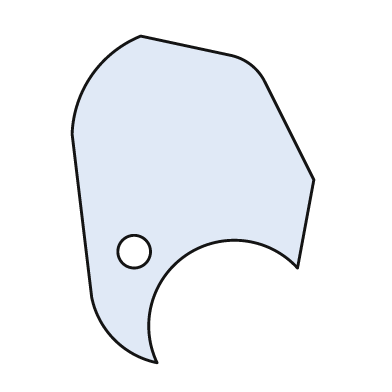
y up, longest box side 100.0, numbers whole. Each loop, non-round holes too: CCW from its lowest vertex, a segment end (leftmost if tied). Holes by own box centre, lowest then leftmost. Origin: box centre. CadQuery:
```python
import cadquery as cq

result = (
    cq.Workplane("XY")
    .moveTo(-11.0, -50.0)
    .threePointArc((-2.0, -17.0), (32.0, -21.0))
    .lineTo(37.0, 6.0)
    .lineTo(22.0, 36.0)
    .threePointArc((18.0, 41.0), (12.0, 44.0))
    .lineTo(-16.0, 50.0)
    .threePointArc((-31.0, 38.0), (-37.0, 20.0))
    .lineTo(-31.0, -30.0)
    .threePointArc((-24.0, -43.0), (-11.0, -50.0))
    .close()
    .moveTo(-18.0, -16.0)
    .circle(5.0)
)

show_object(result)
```